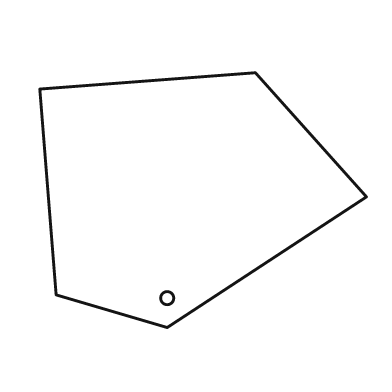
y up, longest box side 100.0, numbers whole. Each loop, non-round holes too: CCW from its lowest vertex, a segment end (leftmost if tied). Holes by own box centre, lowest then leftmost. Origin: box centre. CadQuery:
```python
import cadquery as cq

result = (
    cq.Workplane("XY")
    .moveTo(-11.0, -39.0)
    .lineTo(50.0, 1.0)
    .lineTo(16.0, 39.0)
    .lineTo(-50.0, 34.0)
    .lineTo(-45.0, -29.0)
    .close()
    .moveTo(-11.0, -30.0)
    .circle(2.0)
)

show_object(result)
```